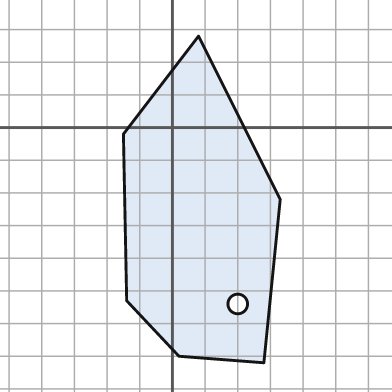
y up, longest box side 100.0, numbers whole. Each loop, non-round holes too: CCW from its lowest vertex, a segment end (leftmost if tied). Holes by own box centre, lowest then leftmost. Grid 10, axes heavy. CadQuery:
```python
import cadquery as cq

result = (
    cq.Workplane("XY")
    .moveTo(28.0, -72.0)
    .lineTo(33.0, -22.0)
    .lineTo(8.0, 28.0)
    .lineTo(-15.0, -2.0)
    .lineTo(-14.0, -53.0)
    .lineTo(2.0, -70.0)
    .close()
    .moveTo(20.0, -54.0)
    .circle(3.0)
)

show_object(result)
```